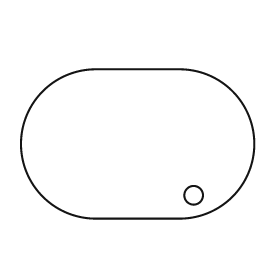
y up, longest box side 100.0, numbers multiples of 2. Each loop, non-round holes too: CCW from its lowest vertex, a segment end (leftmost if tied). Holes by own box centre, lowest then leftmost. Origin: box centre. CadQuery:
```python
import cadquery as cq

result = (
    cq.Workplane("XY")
    .moveTo(-18.0, -32.0)
    .lineTo(18.0, -32.0)
    .threePointArc((50.0, 0.0), (18.0, 32.0))
    .lineTo(-18.0, 32.0)
    .threePointArc((-50.0, 0.0), (-18.0, -32.0))
    .close()
    .moveTo(24.0, -22.0)
    .circle(4.0)
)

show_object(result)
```